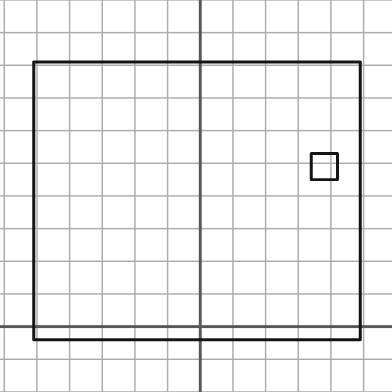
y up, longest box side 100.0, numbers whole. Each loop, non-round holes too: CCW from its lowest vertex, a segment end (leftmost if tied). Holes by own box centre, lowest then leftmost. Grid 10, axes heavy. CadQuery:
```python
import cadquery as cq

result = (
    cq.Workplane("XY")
    .moveTo(-51.0, -4.0)
    .lineTo(49.0, -4.0)
    .lineTo(49.0, 81.0)
    .lineTo(-51.0, 81.0)
    .close()
    .moveTo(34.0, 45.0)
    .lineTo(42.0, 45.0)
    .lineTo(42.0, 53.0)
    .lineTo(34.0, 53.0)
    .close()
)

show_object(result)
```